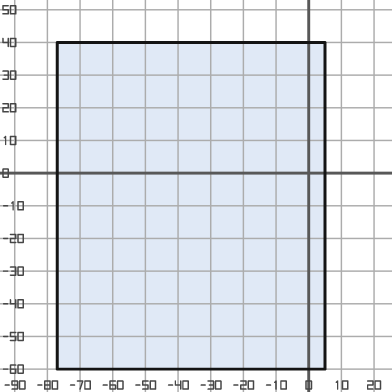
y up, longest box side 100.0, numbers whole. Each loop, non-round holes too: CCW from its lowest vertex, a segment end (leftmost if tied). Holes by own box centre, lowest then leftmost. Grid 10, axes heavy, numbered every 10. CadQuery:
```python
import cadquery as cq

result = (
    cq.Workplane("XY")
    .moveTo(-77.0, -60.0)
    .lineTo(5.0, -60.0)
    .lineTo(5.0, 40.0)
    .lineTo(-77.0, 40.0)
    .close()
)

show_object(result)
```